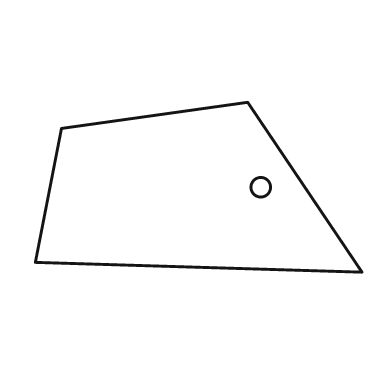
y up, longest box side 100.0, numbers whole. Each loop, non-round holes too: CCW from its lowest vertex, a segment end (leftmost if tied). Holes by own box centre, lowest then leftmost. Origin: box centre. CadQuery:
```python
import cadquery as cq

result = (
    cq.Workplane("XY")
    .moveTo(50.0, -26.0)
    .lineTo(15.0, 26.0)
    .lineTo(-42.0, 18.0)
    .lineTo(-50.0, -23.0)
    .close()
    .moveTo(19.0, 0.0)
    .circle(3.0)
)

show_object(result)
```